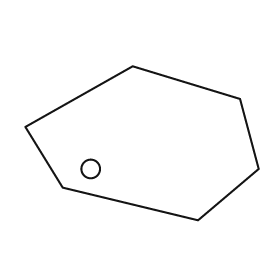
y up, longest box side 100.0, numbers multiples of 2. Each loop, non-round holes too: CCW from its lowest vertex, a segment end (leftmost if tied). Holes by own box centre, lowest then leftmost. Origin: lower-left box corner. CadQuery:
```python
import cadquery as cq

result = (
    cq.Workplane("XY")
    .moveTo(74.0, 0.0)
    .lineTo(100.0, 22.0)
    .lineTo(92.0, 52.0)
    .lineTo(46.0, 66.0)
    .lineTo(0.0, 40.0)
    .lineTo(16.0, 14.0)
    .close()
    .moveTo(28.0, 22.0)
    .circle(4.0)
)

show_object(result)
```